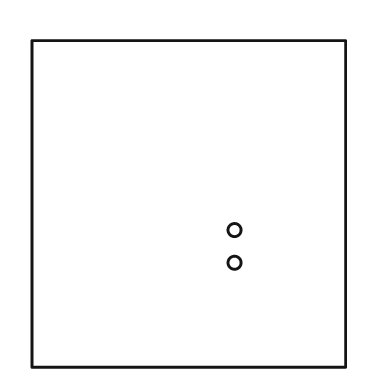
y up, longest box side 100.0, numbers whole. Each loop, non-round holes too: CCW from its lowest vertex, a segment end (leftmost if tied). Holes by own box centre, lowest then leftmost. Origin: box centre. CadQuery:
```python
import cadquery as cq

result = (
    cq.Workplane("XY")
    .moveTo(-48.0, -50.0)
    .lineTo(48.0, -50.0)
    .lineTo(48.0, 50.0)
    .lineTo(-48.0, 50.0)
    .close()
    .moveTo(14.0, -18.0)
    .circle(2.0)
    .moveTo(14.0, -8.0)
    .circle(2.0)
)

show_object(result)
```